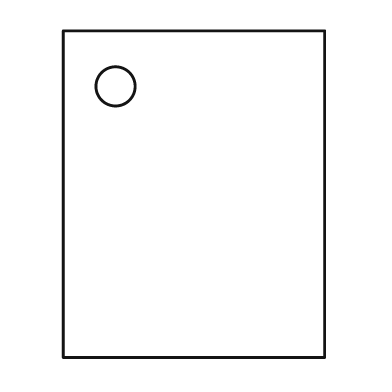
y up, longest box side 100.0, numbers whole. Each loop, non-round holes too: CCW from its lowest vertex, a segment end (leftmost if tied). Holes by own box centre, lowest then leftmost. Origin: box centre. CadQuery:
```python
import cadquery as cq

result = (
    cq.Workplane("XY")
    .moveTo(-40.0, -50.0)
    .lineTo(40.0, -50.0)
    .lineTo(40.0, 50.0)
    .lineTo(-40.0, 50.0)
    .close()
    .moveTo(-24.0, 33.0)
    .circle(6.0)
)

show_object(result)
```